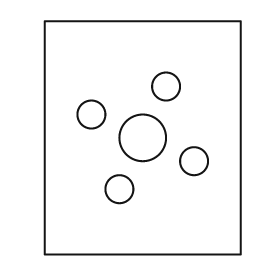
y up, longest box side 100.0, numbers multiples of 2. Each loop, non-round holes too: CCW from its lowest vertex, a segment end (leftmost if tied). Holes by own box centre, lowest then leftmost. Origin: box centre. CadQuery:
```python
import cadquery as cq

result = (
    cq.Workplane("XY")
    .moveTo(-42.0, -50.0)
    .lineTo(42.0, -50.0)
    .lineTo(42.0, 50.0)
    .lineTo(-42.0, 50.0)
    .close()
    .moveTo(-10.0, -22.0)
    .circle(6.0)
    .moveTo(22.0, -10.0)
    .circle(6.0)
    .moveTo(0.0, 0.0)
    .circle(10.0)
    .moveTo(-22.0, 10.0)
    .circle(6.0)
    .moveTo(10.0, 22.0)
    .circle(6.0)
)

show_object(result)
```